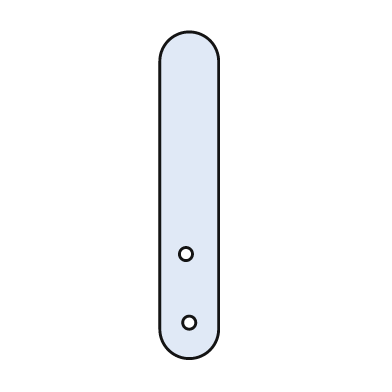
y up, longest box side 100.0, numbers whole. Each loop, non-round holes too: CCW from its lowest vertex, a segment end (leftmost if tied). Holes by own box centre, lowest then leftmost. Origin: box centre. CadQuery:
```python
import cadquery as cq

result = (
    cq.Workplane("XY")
    .moveTo(-9.0, -41.0)
    .threePointArc((0.0, -50.0), (9.0, -41.0))
    .lineTo(9.0, 41.0)
    .threePointArc((0.0, 50.0), (-9.0, 41.0))
    .close()
    .moveTo(0.0, -39.0)
    .circle(2.0)
    .moveTo(-1.0, -18.0)
    .circle(2.0)
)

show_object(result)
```